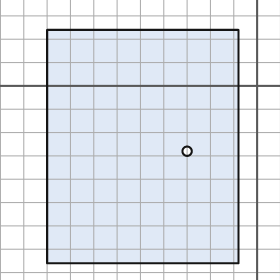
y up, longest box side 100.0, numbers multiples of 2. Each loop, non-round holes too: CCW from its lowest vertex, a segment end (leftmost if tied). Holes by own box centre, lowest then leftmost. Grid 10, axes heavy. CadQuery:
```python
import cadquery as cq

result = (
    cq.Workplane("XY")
    .moveTo(-90.0, -76.0)
    .lineTo(-8.0, -76.0)
    .lineTo(-8.0, 24.0)
    .lineTo(-90.0, 24.0)
    .close()
    .moveTo(-30.0, -28.0)
    .circle(2.0)
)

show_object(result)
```